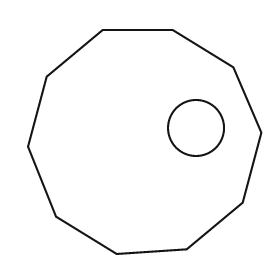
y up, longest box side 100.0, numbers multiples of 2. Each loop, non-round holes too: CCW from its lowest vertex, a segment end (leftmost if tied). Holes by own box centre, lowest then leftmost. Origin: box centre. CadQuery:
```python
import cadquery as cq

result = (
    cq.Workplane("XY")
    .moveTo(-12.0, -48.0)
    .lineTo(18.0, -46.0)
    .lineTo(42.0, -26.0)
    .lineTo(50.0, 4.0)
    .lineTo(38.0, 32.0)
    .lineTo(12.0, 48.0)
    .lineTo(-18.0, 48.0)
    .lineTo(-42.0, 28.0)
    .lineTo(-50.0, -2.0)
    .lineTo(-38.0, -32.0)
    .close()
    .moveTo(22.0, 6.0)
    .circle(12.0)
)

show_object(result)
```